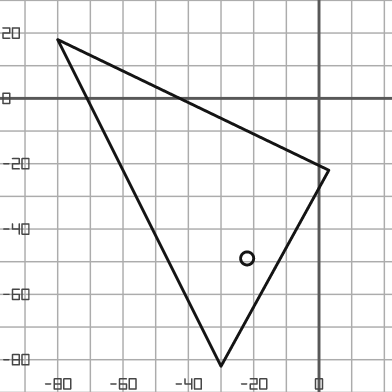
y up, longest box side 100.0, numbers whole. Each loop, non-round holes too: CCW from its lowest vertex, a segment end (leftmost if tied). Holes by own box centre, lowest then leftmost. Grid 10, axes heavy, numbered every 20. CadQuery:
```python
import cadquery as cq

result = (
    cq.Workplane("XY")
    .moveTo(-30.0, -82.0)
    .lineTo(3.0, -22.0)
    .lineTo(-80.0, 18.0)
    .close()
    .moveTo(-22.0, -49.0)
    .circle(2.0)
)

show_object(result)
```